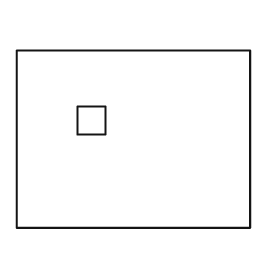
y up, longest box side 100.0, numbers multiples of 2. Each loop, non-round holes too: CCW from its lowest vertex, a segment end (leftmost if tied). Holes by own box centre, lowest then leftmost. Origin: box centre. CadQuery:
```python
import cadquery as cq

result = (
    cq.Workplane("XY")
    .moveTo(-50.0, -38.0)
    .lineTo(50.0, -38.0)
    .lineTo(50.0, 38.0)
    .lineTo(-50.0, 38.0)
    .close()
    .moveTo(-24.0, 2.0)
    .lineTo(-12.0, 2.0)
    .lineTo(-12.0, 14.0)
    .lineTo(-24.0, 14.0)
    .close()
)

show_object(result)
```